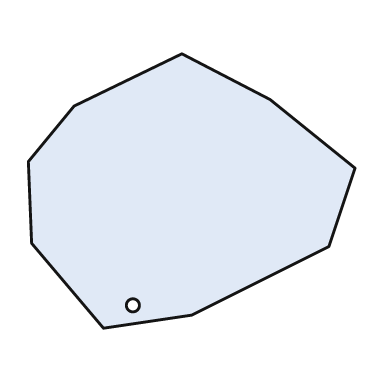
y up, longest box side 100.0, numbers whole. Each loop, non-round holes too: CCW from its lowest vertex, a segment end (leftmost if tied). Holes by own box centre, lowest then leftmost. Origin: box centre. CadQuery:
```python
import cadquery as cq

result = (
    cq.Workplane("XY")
    .moveTo(-27.0, -42.0)
    .lineTo(0.0, -38.0)
    .lineTo(42.0, -17.0)
    .lineTo(50.0, 7.0)
    .lineTo(24.0, 28.0)
    .lineTo(-3.0, 42.0)
    .lineTo(-36.0, 26.0)
    .lineTo(-50.0, 9.0)
    .lineTo(-49.0, -16.0)
    .close()
    .moveTo(-18.0, -35.0)
    .circle(2.0)
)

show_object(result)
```